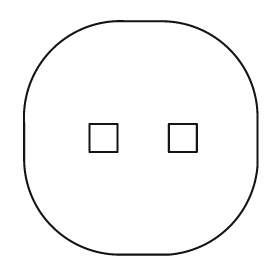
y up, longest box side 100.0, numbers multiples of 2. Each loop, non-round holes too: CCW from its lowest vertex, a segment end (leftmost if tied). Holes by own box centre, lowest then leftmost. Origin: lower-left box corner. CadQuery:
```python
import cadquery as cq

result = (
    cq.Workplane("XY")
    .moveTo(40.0, 0.0)
    .lineTo(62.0, 0.0)
    .threePointArc((88.0, 12.0), (100.0, 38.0))
    .lineTo(100.0, 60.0)
    .threePointArc((88.0, 88.0), (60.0, 100.0))
    .lineTo(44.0, 100.0)
    .threePointArc((12.0, 88.0), (0.0, 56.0))
    .lineTo(0.0, 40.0)
    .threePointArc((12.0, 12.0), (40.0, 0.0))
    .close()
    .moveTo(28.0, 44.0)
    .lineTo(40.0, 44.0)
    .lineTo(40.0, 56.0)
    .lineTo(28.0, 56.0)
    .close()
    .moveTo(62.0, 44.0)
    .lineTo(74.0, 44.0)
    .lineTo(74.0, 56.0)
    .lineTo(62.0, 56.0)
    .close()
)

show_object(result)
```